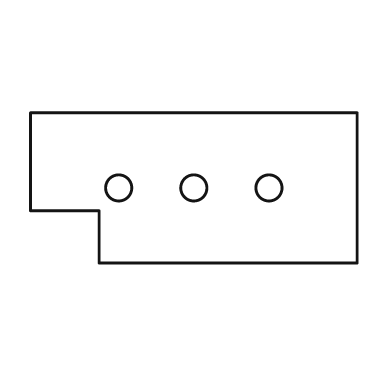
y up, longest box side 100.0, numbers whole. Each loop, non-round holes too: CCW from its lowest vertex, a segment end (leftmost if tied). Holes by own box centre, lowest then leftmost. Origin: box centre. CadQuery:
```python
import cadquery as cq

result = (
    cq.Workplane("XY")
    .moveTo(-29.0, -23.0)
    .lineTo(50.0, -23.0)
    .lineTo(50.0, 23.0)
    .lineTo(-50.0, 23.0)
    .lineTo(-50.0, -7.0)
    .lineTo(-29.0, -7.0)
    .close()
    .moveTo(-23.0, 0.0)
    .circle(4.0)
    .moveTo(0.0, 0.0)
    .circle(4.0)
    .moveTo(23.0, 0.0)
    .circle(4.0)
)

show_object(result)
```